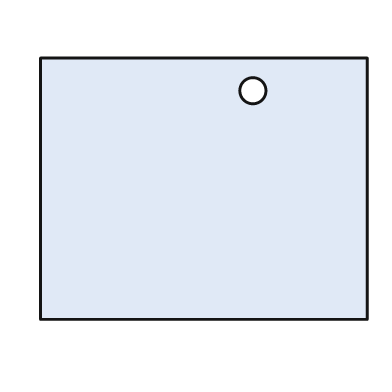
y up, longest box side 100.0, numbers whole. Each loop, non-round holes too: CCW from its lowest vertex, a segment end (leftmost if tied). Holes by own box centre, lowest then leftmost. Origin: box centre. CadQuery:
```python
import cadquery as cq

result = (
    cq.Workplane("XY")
    .moveTo(-50.0, -40.0)
    .lineTo(50.0, -40.0)
    .lineTo(50.0, 40.0)
    .lineTo(-50.0, 40.0)
    .close()
    .moveTo(15.0, 30.0)
    .circle(4.0)
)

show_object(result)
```